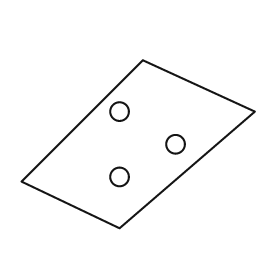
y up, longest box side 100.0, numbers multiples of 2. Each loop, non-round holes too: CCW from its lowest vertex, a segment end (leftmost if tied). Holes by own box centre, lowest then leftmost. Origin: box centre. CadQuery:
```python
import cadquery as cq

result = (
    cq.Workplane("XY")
    .moveTo(-8.0, -36.0)
    .lineTo(50.0, 14.0)
    .lineTo(2.0, 36.0)
    .lineTo(-50.0, -16.0)
    .close()
    .moveTo(-8.0, -14.0)
    .circle(4.0)
    .moveTo(16.0, 0.0)
    .circle(4.0)
    .moveTo(-8.0, 14.0)
    .circle(4.0)
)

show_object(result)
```